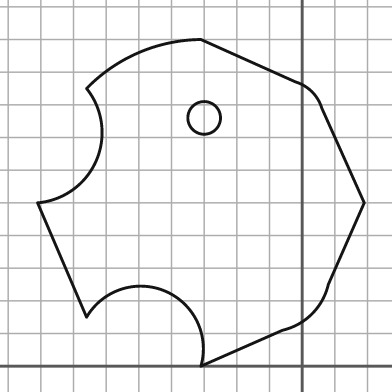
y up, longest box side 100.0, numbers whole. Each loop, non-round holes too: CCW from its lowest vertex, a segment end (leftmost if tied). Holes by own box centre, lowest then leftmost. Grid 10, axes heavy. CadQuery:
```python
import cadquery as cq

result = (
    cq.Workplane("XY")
    .moveTo(-31.0, 0.0)
    .lineTo(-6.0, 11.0)
    .threePointArc((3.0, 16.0), (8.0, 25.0))
    .lineTo(19.0, 50.0)
    .lineTo(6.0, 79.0)
    .threePointArc((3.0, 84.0), (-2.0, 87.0))
    .lineTo(-31.0, 100.0)
    .threePointArc((-50.0, 96.0), (-66.0, 85.0))
    .threePointArc((-63.0, 63.0), (-81.0, 50.0))
    .lineTo(-66.0, 15.0)
    .threePointArc((-42.0, 23.0), (-31.0, 0.0))
    .close()
    .moveTo(-30.0, 76.0)
    .circle(5.0)
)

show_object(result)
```